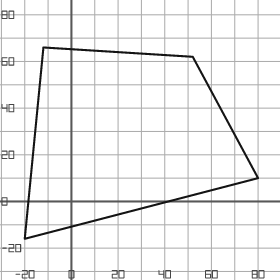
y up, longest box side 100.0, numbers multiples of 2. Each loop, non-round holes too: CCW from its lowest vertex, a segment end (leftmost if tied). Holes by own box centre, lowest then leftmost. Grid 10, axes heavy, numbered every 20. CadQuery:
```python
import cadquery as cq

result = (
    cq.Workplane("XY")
    .moveTo(-20.0, -16.0)
    .lineTo(80.0, 10.0)
    .lineTo(52.0, 62.0)
    .lineTo(-12.0, 66.0)
    .close()
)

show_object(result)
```